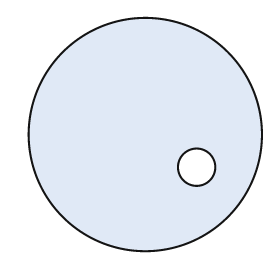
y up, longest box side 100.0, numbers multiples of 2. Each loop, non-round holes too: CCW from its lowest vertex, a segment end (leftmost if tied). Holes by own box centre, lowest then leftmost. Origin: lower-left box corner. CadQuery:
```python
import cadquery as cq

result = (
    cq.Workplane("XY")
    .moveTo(50.0, 50.0)
    .circle(50.0)
    .moveTo(72.0, 36.0)
    .circle(8.0)
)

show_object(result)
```